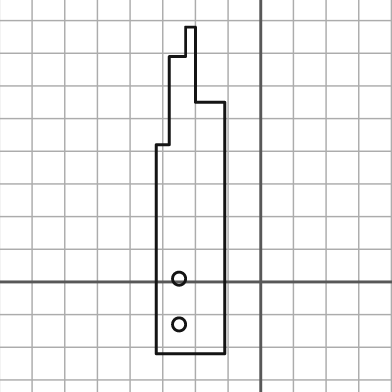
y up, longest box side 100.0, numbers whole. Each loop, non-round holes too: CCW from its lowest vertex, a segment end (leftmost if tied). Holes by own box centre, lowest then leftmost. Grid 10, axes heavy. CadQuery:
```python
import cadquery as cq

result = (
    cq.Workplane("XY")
    .moveTo(-32.0, -22.0)
    .lineTo(-11.0, -22.0)
    .lineTo(-11.0, 55.0)
    .lineTo(-20.0, 55.0)
    .lineTo(-20.0, 78.0)
    .lineTo(-23.0, 78.0)
    .lineTo(-23.0, 69.0)
    .lineTo(-28.0, 69.0)
    .lineTo(-28.0, 42.0)
    .lineTo(-32.0, 42.0)
    .close()
    .moveTo(-25.0, -13.0)
    .circle(2.0)
    .moveTo(-25.0, 1.0)
    .circle(2.0)
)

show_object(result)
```